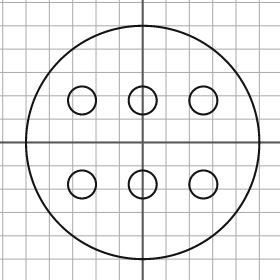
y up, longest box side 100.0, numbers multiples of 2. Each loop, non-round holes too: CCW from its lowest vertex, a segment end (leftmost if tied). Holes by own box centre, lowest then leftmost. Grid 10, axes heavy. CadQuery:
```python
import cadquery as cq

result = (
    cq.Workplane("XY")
    .moveTo(0.0, 0.0)
    .circle(50.0)
    .moveTo(-26.0, -18.0)
    .circle(6.0)
    .moveTo(0.0, -18.0)
    .circle(6.0)
    .moveTo(26.0, -18.0)
    .circle(6.0)
    .moveTo(-26.0, 18.0)
    .circle(6.0)
    .moveTo(0.0, 18.0)
    .circle(6.0)
    .moveTo(26.0, 18.0)
    .circle(6.0)
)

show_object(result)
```